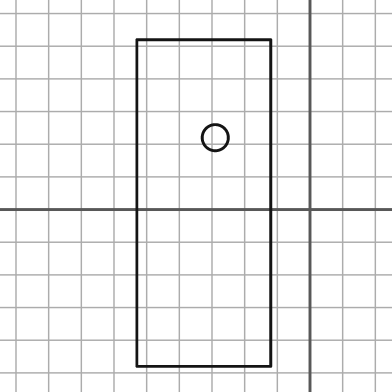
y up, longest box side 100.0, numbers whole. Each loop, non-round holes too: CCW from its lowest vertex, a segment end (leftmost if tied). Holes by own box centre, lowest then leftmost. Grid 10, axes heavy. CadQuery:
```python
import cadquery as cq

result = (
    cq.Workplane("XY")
    .moveTo(-53.0, -48.0)
    .lineTo(-12.0, -48.0)
    .lineTo(-12.0, 52.0)
    .lineTo(-53.0, 52.0)
    .close()
    .moveTo(-29.0, 22.0)
    .circle(4.0)
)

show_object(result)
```